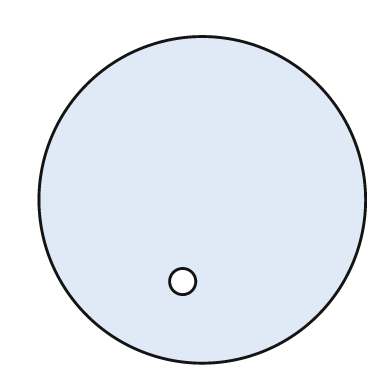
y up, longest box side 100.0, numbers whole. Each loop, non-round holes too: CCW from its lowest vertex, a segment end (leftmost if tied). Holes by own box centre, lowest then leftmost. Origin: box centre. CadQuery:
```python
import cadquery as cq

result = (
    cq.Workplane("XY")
    .moveTo(0.0, 0.0)
    .circle(50.0)
    .moveTo(-6.0, -25.0)
    .circle(4.0)
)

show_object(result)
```